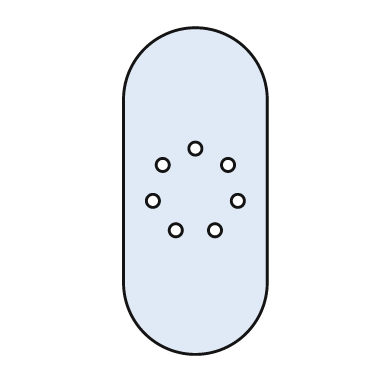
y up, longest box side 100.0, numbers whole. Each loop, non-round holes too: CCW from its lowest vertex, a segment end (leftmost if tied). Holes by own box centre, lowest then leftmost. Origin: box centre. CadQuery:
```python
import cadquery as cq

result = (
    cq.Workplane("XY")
    .moveTo(-22.0, -28.0)
    .threePointArc((0.0, -50.0), (22.0, -28.0))
    .lineTo(22.0, 28.0)
    .threePointArc((0.0, 50.0), (-22.0, 28.0))
    .close()
    .moveTo(-6.0, -12.0)
    .circle(2.0)
    .moveTo(6.0, -12.0)
    .circle(2.0)
    .moveTo(-13.0, -3.0)
    .circle(2.0)
    .moveTo(13.0, -3.0)
    .circle(2.0)
    .moveTo(-10.0, 8.0)
    .circle(2.0)
    .moveTo(10.0, 8.0)
    .circle(2.0)
    .moveTo(0.0, 13.0)
    .circle(2.0)
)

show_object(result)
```